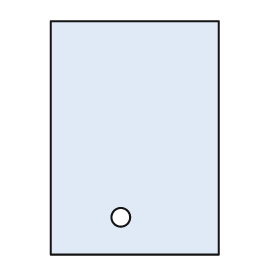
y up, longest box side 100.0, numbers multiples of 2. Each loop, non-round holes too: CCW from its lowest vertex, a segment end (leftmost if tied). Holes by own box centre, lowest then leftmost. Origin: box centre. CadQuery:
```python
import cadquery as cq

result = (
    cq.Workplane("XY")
    .moveTo(-36.0, -50.0)
    .lineTo(36.0, -50.0)
    .lineTo(36.0, 50.0)
    .lineTo(-36.0, 50.0)
    .close()
    .moveTo(-6.0, -34.0)
    .circle(4.0)
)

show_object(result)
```